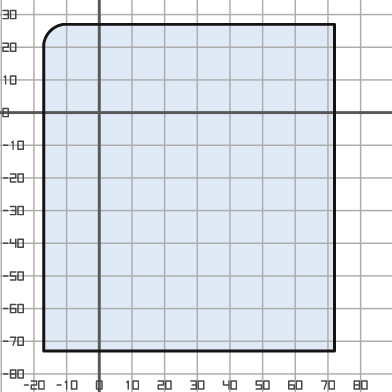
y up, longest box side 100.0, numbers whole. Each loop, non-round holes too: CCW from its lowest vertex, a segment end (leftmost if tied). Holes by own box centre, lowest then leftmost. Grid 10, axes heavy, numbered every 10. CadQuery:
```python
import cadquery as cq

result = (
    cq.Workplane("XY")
    .moveTo(-17.0, -73.0)
    .lineTo(72.0, -73.0)
    .lineTo(72.0, 27.0)
    .lineTo(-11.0, 27.0)
    .threePointArc((-15.0, 25.0), (-17.0, 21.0))
    .close()
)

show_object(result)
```